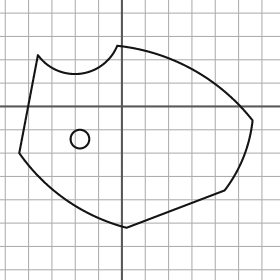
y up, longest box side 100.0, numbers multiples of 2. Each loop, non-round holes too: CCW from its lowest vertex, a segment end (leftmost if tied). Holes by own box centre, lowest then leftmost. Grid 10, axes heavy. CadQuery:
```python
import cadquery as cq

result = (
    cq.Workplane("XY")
    .moveTo(2.0, -52.0)
    .lineTo(44.0, -36.0)
    .threePointArc((52.0, -22.0), (56.0, -6.0))
    .threePointArc((30.0, 16.0), (-2.0, 26.0))
    .threePointArc((-18.0, 14.0), (-36.0, 22.0))
    .lineTo(-44.0, -20.0)
    .threePointArc((-24.0, -40.0), (2.0, -52.0))
    .close()
    .moveTo(-18.0, -14.0)
    .circle(4.0)
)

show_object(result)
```